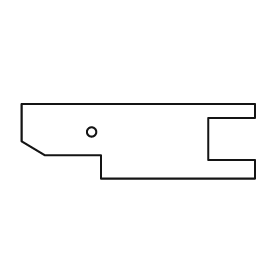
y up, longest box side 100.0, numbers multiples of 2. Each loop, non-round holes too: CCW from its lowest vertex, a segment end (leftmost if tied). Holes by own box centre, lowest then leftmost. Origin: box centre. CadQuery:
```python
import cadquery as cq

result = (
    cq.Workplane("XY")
    .moveTo(-16.0, -16.0)
    .lineTo(50.0, -16.0)
    .lineTo(50.0, -8.0)
    .lineTo(30.0, -8.0)
    .lineTo(30.0, 10.0)
    .lineTo(50.0, 10.0)
    .lineTo(50.0, 16.0)
    .lineTo(-50.0, 16.0)
    .lineTo(-50.0, 0.0)
    .lineTo(-40.0, -6.0)
    .lineTo(-16.0, -6.0)
    .close()
    .moveTo(-20.0, 4.0)
    .circle(2.0)
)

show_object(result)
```